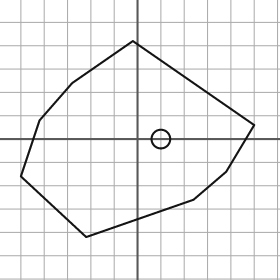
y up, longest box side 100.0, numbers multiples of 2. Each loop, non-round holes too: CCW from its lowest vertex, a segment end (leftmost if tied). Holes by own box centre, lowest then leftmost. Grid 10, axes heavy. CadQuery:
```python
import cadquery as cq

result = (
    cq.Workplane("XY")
    .moveTo(-22.0, -42.0)
    .lineTo(24.0, -26.0)
    .lineTo(38.0, -14.0)
    .lineTo(50.0, 6.0)
    .lineTo(-2.0, 42.0)
    .lineTo(-28.0, 24.0)
    .lineTo(-42.0, 8.0)
    .lineTo(-50.0, -16.0)
    .close()
    .moveTo(10.0, 0.0)
    .circle(4.0)
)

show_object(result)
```